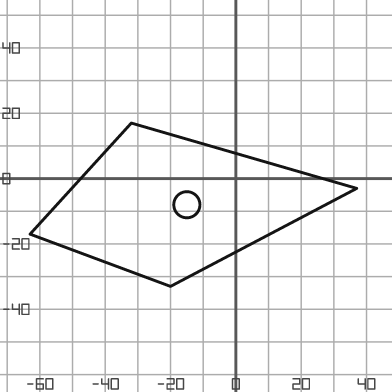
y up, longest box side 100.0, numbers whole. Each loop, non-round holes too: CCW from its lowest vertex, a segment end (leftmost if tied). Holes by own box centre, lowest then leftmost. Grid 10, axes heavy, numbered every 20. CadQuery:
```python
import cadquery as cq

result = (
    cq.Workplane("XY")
    .moveTo(-20.0, -33.0)
    .lineTo(37.0, -3.0)
    .lineTo(-32.0, 17.0)
    .lineTo(-63.0, -17.0)
    .close()
    .moveTo(-15.0, -8.0)
    .circle(4.0)
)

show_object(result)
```